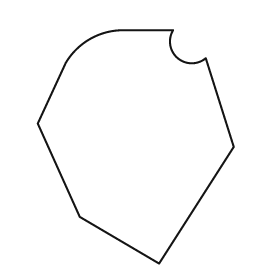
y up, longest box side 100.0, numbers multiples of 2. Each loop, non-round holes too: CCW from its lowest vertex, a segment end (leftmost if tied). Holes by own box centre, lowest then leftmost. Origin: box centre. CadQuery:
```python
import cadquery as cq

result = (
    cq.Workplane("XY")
    .moveTo(10.0, -50.0)
    .lineTo(42.0, 0.0)
    .lineTo(30.0, 38.0)
    .threePointArc((18.0, 38.0), (16.0, 50.0))
    .lineTo(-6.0, 50.0)
    .threePointArc((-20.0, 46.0), (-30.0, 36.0))
    .lineTo(-42.0, 10.0)
    .lineTo(-24.0, -30.0)
    .close()
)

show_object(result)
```